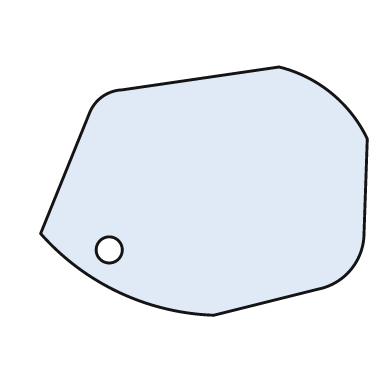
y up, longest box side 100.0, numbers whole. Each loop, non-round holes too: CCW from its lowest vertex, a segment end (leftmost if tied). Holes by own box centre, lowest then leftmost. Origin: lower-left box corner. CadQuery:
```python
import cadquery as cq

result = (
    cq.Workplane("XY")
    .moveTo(53.0, 0.0)
    .lineTo(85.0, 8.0)
    .threePointArc((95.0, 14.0), (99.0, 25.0))
    .lineTo(100.0, 54.0)
    .threePointArc((89.0, 68.0), (73.0, 76.0))
    .lineTo(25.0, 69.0)
    .threePointArc((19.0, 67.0), (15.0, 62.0))
    .lineTo(0.0, 25.0)
    .threePointArc((24.0, 7.0), (53.0, 0.0))
    .close()
    .moveTo(21.0, 20.0)
    .circle(4.0)
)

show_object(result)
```